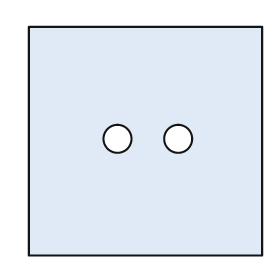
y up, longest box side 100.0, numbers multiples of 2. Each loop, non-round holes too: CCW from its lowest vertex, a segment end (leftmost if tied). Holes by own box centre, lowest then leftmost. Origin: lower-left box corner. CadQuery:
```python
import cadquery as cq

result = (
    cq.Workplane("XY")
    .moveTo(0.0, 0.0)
    .lineTo(100.0, 0.0)
    .lineTo(100.0, 98.0)
    .lineTo(0.0, 98.0)
    .close()
    .moveTo(38.0, 50.0)
    .circle(6.0)
    .moveTo(64.0, 50.0)
    .circle(6.0)
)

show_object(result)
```